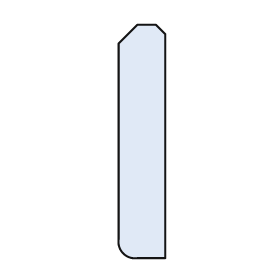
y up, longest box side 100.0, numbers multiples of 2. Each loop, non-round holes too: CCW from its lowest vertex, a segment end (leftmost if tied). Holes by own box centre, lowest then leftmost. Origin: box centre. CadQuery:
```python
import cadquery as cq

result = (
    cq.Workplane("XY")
    .moveTo(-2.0, -50.0)
    .lineTo(10.0, -50.0)
    .lineTo(10.0, 46.0)
    .lineTo(6.0, 50.0)
    .lineTo(-2.0, 50.0)
    .lineTo(-10.0, 42.0)
    .lineTo(-10.0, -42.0)
    .threePointArc((-8.0, -48.0), (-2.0, -50.0))
    .close()
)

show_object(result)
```